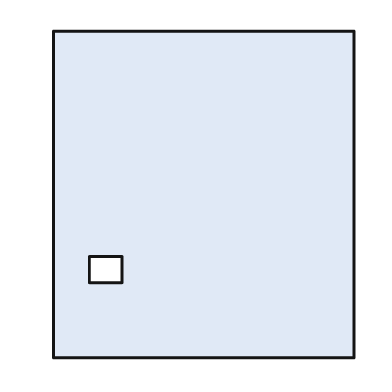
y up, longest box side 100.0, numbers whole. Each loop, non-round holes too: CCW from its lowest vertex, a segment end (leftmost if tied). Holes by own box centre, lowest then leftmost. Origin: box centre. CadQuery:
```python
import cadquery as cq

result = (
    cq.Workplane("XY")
    .moveTo(-46.0, -50.0)
    .lineTo(46.0, -50.0)
    .lineTo(46.0, 50.0)
    .lineTo(-46.0, 50.0)
    .close()
    .moveTo(-35.0, -27.0)
    .lineTo(-25.0, -27.0)
    .lineTo(-25.0, -19.0)
    .lineTo(-35.0, -19.0)
    .close()
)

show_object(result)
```